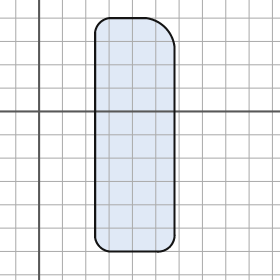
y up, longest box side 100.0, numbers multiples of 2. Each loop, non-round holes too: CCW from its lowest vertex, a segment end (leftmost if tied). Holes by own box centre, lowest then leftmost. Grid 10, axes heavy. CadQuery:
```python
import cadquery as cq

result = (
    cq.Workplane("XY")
    .moveTo(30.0, -60.0)
    .lineTo(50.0, -60.0)
    .threePointArc((56.0, -58.0), (58.0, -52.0))
    .lineTo(58.0, 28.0)
    .threePointArc((54.0, 36.0), (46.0, 40.0))
    .lineTo(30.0, 40.0)
    .threePointArc((26.0, 38.0), (24.0, 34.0))
    .lineTo(24.0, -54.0)
    .threePointArc((26.0, -58.0), (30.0, -60.0))
    .close()
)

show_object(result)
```